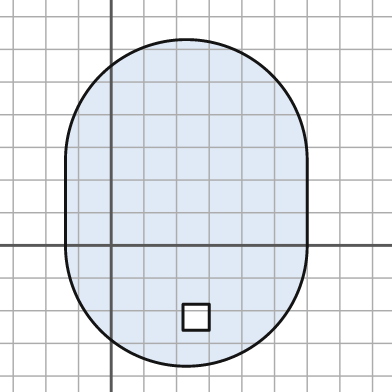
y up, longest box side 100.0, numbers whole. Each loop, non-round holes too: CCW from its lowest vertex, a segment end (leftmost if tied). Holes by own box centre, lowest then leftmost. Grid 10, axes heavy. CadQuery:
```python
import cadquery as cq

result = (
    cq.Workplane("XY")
    .moveTo(-14.0, 0.0)
    .threePointArc((23.0, -37.0), (60.0, 0.0))
    .lineTo(60.0, 26.0)
    .threePointArc((23.0, 63.0), (-14.0, 26.0))
    .close()
    .moveTo(22.0, -26.0)
    .lineTo(30.0, -26.0)
    .lineTo(30.0, -18.0)
    .lineTo(22.0, -18.0)
    .close()
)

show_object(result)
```